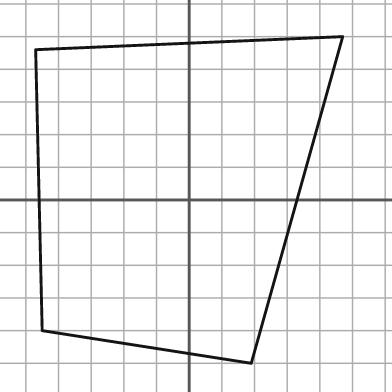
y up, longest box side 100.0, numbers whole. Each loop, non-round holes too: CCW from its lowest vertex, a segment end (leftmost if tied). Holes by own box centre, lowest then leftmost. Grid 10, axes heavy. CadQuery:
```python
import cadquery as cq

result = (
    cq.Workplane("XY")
    .moveTo(19.0, -50.0)
    .lineTo(47.0, 50.0)
    .lineTo(-47.0, 46.0)
    .lineTo(-45.0, -40.0)
    .close()
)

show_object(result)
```